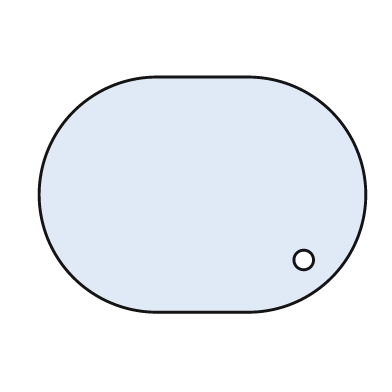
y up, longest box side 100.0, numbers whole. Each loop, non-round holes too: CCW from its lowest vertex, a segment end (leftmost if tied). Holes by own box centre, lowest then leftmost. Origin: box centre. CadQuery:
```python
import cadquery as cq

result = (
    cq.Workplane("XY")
    .moveTo(-14.0, -36.0)
    .lineTo(14.0, -36.0)
    .threePointArc((50.0, 0.0), (14.0, 36.0))
    .lineTo(-14.0, 36.0)
    .threePointArc((-50.0, 0.0), (-14.0, -36.0))
    .close()
    .moveTo(31.0, -20.0)
    .circle(3.0)
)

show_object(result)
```